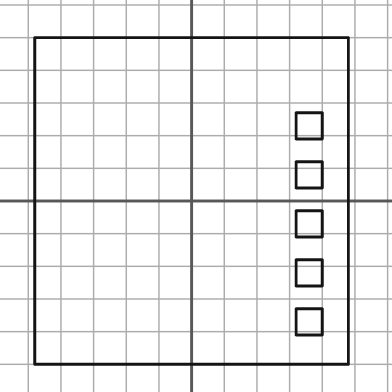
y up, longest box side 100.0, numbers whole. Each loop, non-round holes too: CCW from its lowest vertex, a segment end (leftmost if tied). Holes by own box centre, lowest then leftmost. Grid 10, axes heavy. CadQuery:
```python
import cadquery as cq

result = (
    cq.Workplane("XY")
    .moveTo(-48.0, -50.0)
    .lineTo(48.0, -50.0)
    .lineTo(48.0, 50.0)
    .lineTo(-48.0, 50.0)
    .close()
    .moveTo(32.0, -41.0)
    .lineTo(40.0, -41.0)
    .lineTo(40.0, -33.0)
    .lineTo(32.0, -33.0)
    .close()
    .moveTo(32.0, -26.0)
    .lineTo(40.0, -26.0)
    .lineTo(40.0, -18.0)
    .lineTo(32.0, -18.0)
    .close()
    .moveTo(32.0, -11.0)
    .lineTo(40.0, -11.0)
    .lineTo(40.0, -3.0)
    .lineTo(32.0, -3.0)
    .close()
    .moveTo(32.0, 4.0)
    .lineTo(40.0, 4.0)
    .lineTo(40.0, 12.0)
    .lineTo(32.0, 12.0)
    .close()
    .moveTo(32.0, 19.0)
    .lineTo(40.0, 19.0)
    .lineTo(40.0, 27.0)
    .lineTo(32.0, 27.0)
    .close()
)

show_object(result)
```